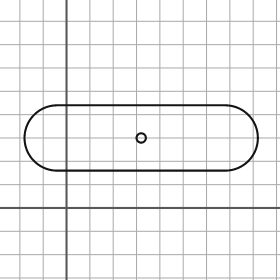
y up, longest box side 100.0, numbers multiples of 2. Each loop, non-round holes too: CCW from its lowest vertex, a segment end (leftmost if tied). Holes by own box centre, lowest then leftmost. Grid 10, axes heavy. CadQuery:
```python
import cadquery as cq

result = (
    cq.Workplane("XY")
    .moveTo(-4.0, 16.0)
    .lineTo(68.0, 16.0)
    .threePointArc((82.0, 30.0), (68.0, 44.0))
    .lineTo(-4.0, 44.0)
    .threePointArc((-18.0, 30.0), (-4.0, 16.0))
    .close()
    .moveTo(32.0, 30.0)
    .circle(2.0)
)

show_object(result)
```